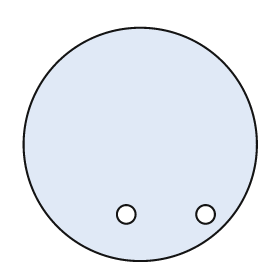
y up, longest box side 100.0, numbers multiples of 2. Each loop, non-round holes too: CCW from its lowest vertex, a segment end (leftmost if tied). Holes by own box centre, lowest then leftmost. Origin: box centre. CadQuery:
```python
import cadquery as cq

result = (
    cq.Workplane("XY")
    .moveTo(0.0, 0.0)
    .circle(50.0)
    .moveTo(-6.0, -30.0)
    .circle(4.0)
    .moveTo(28.0, -30.0)
    .circle(4.0)
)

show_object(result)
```